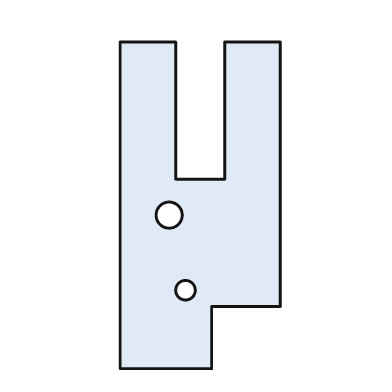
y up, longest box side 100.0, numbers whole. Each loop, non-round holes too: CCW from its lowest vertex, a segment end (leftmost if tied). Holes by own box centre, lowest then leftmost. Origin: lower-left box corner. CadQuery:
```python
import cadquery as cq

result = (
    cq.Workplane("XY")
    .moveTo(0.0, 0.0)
    .lineTo(28.0, 0.0)
    .lineTo(28.0, 19.0)
    .lineTo(49.0, 19.0)
    .lineTo(49.0, 100.0)
    .lineTo(32.0, 100.0)
    .lineTo(32.0, 58.0)
    .lineTo(17.0, 58.0)
    .lineTo(17.0, 100.0)
    .lineTo(0.0, 100.0)
    .close()
    .moveTo(20.0, 24.0)
    .circle(3.0)
    .moveTo(15.0, 47.0)
    .circle(4.0)
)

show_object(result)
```